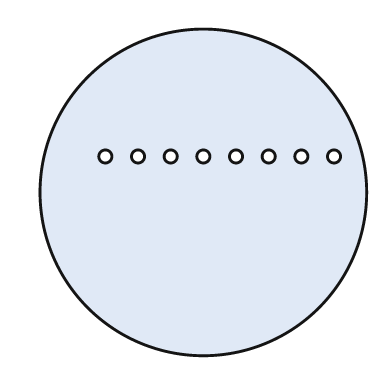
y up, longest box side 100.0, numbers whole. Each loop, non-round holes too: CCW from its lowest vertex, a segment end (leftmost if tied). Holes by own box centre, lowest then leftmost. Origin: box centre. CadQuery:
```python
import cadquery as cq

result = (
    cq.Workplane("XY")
    .moveTo(0.0, 0.0)
    .circle(50.0)
    .moveTo(-30.0, 11.0)
    .circle(2.0)
    .moveTo(-20.0, 11.0)
    .circle(2.0)
    .moveTo(-10.0, 11.0)
    .circle(2.0)
    .moveTo(0.0, 11.0)
    .circle(2.0)
    .moveTo(10.0, 11.0)
    .circle(2.0)
    .moveTo(20.0, 11.0)
    .circle(2.0)
    .moveTo(30.0, 11.0)
    .circle(2.0)
    .moveTo(40.0, 11.0)
    .circle(2.0)
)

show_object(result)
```